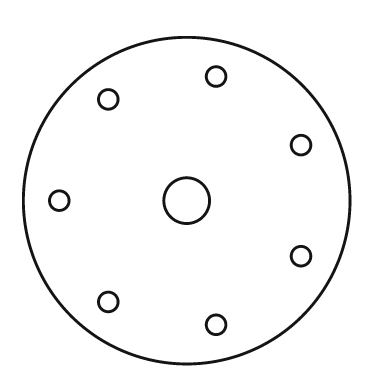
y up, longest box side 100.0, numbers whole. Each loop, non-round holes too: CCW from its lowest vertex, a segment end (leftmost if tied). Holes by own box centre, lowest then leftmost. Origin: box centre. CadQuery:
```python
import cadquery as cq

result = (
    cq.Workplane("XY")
    .moveTo(0.0, 0.0)
    .circle(50.0)
    .moveTo(9.0, -38.0)
    .circle(3.0)
    .moveTo(-24.0, -31.0)
    .circle(3.0)
    .moveTo(35.0, -17.0)
    .circle(3.0)
    .moveTo(-39.0, 0.0)
    .circle(3.0)
    .moveTo(0.0, 0.0)
    .circle(7.0)
    .moveTo(35.0, 17.0)
    .circle(3.0)
    .moveTo(-24.0, 31.0)
    .circle(3.0)
    .moveTo(9.0, 38.0)
    .circle(3.0)
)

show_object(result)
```